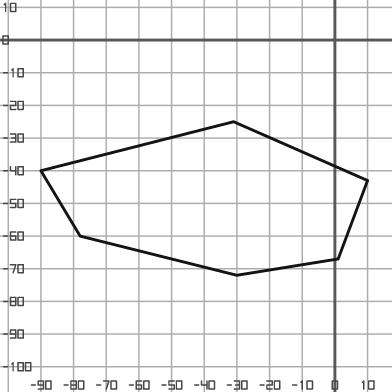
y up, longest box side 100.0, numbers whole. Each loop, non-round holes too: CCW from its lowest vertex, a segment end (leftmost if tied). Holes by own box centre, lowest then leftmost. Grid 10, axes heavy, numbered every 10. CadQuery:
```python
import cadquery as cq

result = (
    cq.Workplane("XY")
    .moveTo(-30.0, -72.0)
    .lineTo(1.0, -67.0)
    .lineTo(10.0, -43.0)
    .lineTo(-31.0, -25.0)
    .lineTo(-90.0, -40.0)
    .lineTo(-78.0, -60.0)
    .close()
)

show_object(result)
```